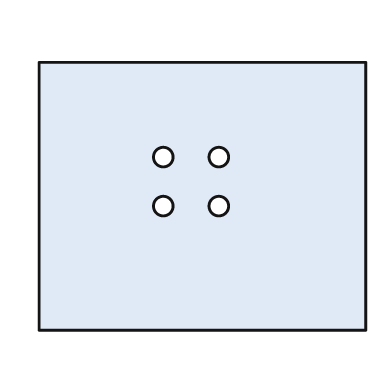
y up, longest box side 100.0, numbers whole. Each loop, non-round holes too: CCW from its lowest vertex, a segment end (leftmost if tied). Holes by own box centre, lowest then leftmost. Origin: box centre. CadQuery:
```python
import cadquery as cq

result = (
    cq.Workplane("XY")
    .moveTo(-50.0, -41.0)
    .lineTo(50.0, -41.0)
    .lineTo(50.0, 41.0)
    .lineTo(-50.0, 41.0)
    .close()
    .moveTo(-12.0, -3.0)
    .circle(3.0)
    .moveTo(5.0, -3.0)
    .circle(3.0)
    .moveTo(-12.0, 12.0)
    .circle(3.0)
    .moveTo(5.0, 12.0)
    .circle(3.0)
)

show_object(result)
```